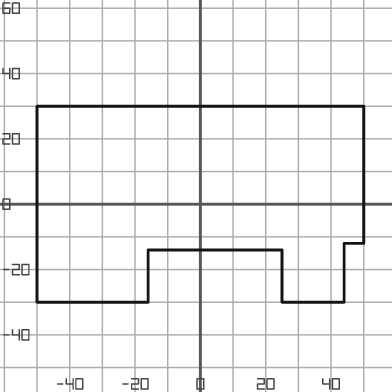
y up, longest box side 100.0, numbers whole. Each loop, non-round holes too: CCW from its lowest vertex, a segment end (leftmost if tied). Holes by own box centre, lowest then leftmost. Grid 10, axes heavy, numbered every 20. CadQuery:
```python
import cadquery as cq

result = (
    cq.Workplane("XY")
    .moveTo(-50.0, -30.0)
    .lineTo(-16.0, -30.0)
    .lineTo(-16.0, -14.0)
    .lineTo(25.0, -14.0)
    .lineTo(25.0, -30.0)
    .lineTo(44.0, -30.0)
    .lineTo(44.0, -12.0)
    .lineTo(50.0, -12.0)
    .lineTo(50.0, 30.0)
    .lineTo(-50.0, 30.0)
    .close()
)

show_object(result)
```